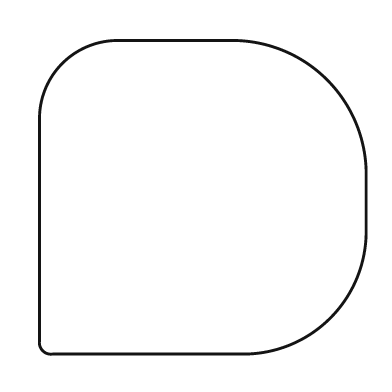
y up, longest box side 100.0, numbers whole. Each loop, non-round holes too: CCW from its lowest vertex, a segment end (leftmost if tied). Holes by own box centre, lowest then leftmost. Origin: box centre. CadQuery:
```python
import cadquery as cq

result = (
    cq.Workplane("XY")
    .moveTo(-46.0, -48.0)
    .lineTo(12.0, -48.0)
    .threePointArc((39.0, -37.0), (50.0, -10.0))
    .lineTo(50.0, 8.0)
    .threePointArc((38.0, 36.0), (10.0, 48.0))
    .lineTo(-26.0, 48.0)
    .threePointArc((-43.0, 41.0), (-50.0, 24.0))
    .lineTo(-50.0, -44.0)
    .threePointArc((-49.0, -47.0), (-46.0, -48.0))
    .close()
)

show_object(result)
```